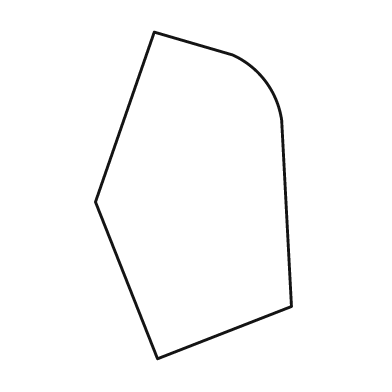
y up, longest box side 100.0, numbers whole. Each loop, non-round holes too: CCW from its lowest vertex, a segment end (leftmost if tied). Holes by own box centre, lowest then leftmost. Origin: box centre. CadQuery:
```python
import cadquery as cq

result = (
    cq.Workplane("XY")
    .moveTo(-11.0, -50.0)
    .lineTo(30.0, -34.0)
    .lineTo(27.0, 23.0)
    .threePointArc((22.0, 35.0), (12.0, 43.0))
    .lineTo(-12.0, 50.0)
    .lineTo(-30.0, -2.0)
    .close()
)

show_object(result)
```